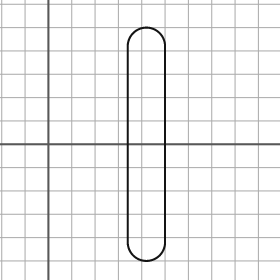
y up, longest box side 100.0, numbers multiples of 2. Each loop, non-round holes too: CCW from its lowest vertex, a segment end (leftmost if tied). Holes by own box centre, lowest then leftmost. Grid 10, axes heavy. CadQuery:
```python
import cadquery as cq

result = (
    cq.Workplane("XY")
    .moveTo(34.0, -42.0)
    .threePointArc((42.0, -50.0), (50.0, -42.0))
    .lineTo(50.0, 42.0)
    .threePointArc((42.0, 50.0), (34.0, 42.0))
    .close()
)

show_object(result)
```